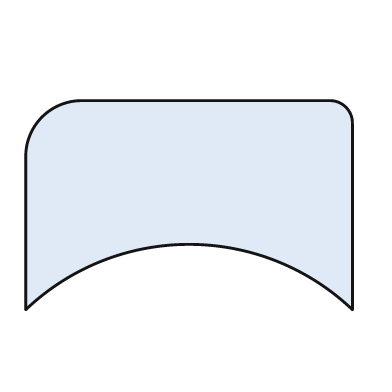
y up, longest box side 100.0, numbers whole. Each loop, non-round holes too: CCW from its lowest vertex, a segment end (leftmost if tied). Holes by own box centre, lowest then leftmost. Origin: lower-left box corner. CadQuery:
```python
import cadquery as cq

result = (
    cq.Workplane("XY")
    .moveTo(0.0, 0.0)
    .threePointArc((50.0, 20.0), (100.0, 0.0))
    .lineTo(100.0, 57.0)
    .threePointArc((98.0, 62.0), (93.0, 64.0))
    .lineTo(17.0, 64.0)
    .threePointArc((5.0, 59.0), (0.0, 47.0))
    .close()
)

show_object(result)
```